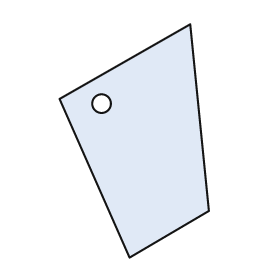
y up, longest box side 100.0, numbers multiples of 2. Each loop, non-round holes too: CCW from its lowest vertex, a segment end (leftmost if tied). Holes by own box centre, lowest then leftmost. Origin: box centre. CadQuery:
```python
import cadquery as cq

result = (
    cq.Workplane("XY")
    .moveTo(-2.0, -50.0)
    .lineTo(32.0, -30.0)
    .lineTo(24.0, 50.0)
    .lineTo(-32.0, 18.0)
    .close()
    .moveTo(-14.0, 16.0)
    .circle(4.0)
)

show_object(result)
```